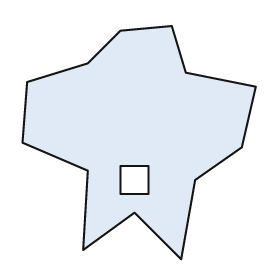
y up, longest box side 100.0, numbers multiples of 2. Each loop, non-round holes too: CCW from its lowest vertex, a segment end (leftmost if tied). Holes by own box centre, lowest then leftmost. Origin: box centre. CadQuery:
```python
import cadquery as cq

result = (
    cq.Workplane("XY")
    .moveTo(18.0, -50.0)
    .lineTo(24.0, -16.0)
    .lineTo(44.0, -2.0)
    .lineTo(50.0, 24.0)
    .lineTo(20.0, 30.0)
    .lineTo(14.0, 50.0)
    .lineTo(-8.0, 48.0)
    .lineTo(-22.0, 34.0)
    .lineTo(-48.0, 26.0)
    .lineTo(-50.0, 0.0)
    .lineTo(-22.0, -12.0)
    .lineTo(-24.0, -46.0)
    .lineTo(-2.0, -30.0)
    .close()
    .moveTo(-8.0, -22.0)
    .lineTo(4.0, -22.0)
    .lineTo(4.0, -10.0)
    .lineTo(-8.0, -10.0)
    .close()
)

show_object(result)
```